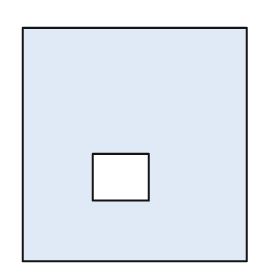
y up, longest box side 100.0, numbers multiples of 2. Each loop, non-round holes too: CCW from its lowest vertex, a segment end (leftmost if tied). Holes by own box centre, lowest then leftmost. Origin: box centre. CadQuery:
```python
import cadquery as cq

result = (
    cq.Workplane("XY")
    .moveTo(-48.0, -50.0)
    .lineTo(48.0, -50.0)
    .lineTo(48.0, 50.0)
    .lineTo(-48.0, 50.0)
    .close()
    .moveTo(-18.0, -24.0)
    .lineTo(6.0, -24.0)
    .lineTo(6.0, -4.0)
    .lineTo(-18.0, -4.0)
    .close()
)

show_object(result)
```